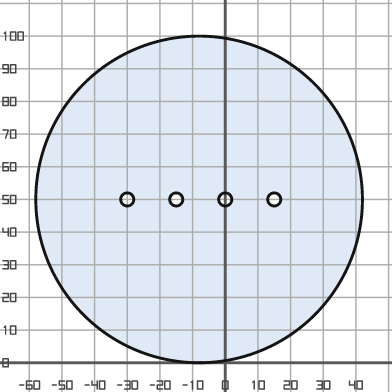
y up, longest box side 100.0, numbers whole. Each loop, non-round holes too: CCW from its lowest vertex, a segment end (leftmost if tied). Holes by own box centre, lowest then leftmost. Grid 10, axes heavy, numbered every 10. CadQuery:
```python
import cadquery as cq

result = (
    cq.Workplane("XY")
    .moveTo(-8.0, 50.0)
    .circle(50.0)
    .moveTo(-30.0, 50.0)
    .circle(2.0)
    .moveTo(-15.0, 50.0)
    .circle(2.0)
    .moveTo(0.0, 50.0)
    .circle(2.0)
    .moveTo(15.0, 50.0)
    .circle(2.0)
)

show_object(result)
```